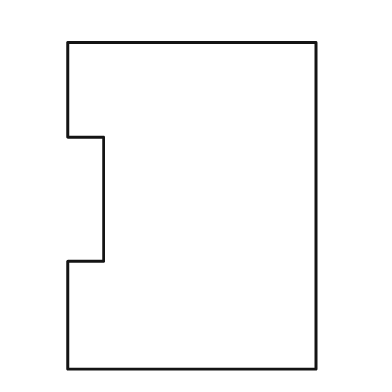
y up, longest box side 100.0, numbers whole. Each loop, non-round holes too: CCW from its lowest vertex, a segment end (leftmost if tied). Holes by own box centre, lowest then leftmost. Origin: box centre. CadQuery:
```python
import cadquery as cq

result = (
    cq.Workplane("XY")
    .moveTo(-38.0, -50.0)
    .lineTo(38.0, -50.0)
    .lineTo(38.0, 50.0)
    .lineTo(-38.0, 50.0)
    .lineTo(-38.0, 21.0)
    .lineTo(-27.0, 21.0)
    .lineTo(-27.0, -17.0)
    .lineTo(-38.0, -17.0)
    .close()
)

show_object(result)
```